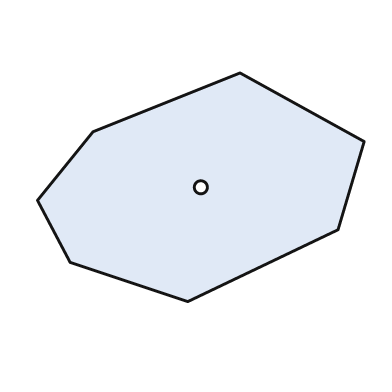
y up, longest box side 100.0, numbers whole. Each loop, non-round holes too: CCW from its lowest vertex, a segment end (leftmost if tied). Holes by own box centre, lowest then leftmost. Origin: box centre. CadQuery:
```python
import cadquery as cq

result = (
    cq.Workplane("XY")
    .moveTo(-4.0, -35.0)
    .lineTo(42.0, -13.0)
    .lineTo(50.0, 14.0)
    .lineTo(12.0, 35.0)
    .lineTo(-33.0, 17.0)
    .lineTo(-50.0, -4.0)
    .lineTo(-40.0, -23.0)
    .close()
    .moveTo(0.0, 0.0)
    .circle(2.0)
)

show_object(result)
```